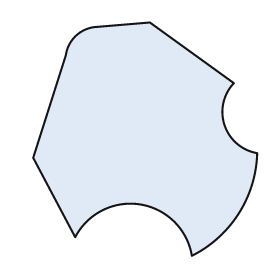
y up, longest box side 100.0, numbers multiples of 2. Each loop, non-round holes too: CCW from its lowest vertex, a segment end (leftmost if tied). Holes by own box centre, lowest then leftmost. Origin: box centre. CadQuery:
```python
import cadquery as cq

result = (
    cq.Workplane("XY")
    .moveTo(20.0, -50.0)
    .threePointArc((40.0, -32.0), (48.0, -6.0))
    .threePointArc((34.0, 6.0), (38.0, 24.0))
    .lineTo(2.0, 50.0)
    .lineTo(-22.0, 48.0)
    .threePointArc((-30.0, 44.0), (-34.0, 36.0))
    .lineTo(-48.0, -8.0)
    .lineTo(-30.0, -42.0)
    .threePointArc((-2.0, -28.0), (20.0, -50.0))
    .close()
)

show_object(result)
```